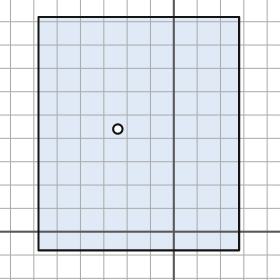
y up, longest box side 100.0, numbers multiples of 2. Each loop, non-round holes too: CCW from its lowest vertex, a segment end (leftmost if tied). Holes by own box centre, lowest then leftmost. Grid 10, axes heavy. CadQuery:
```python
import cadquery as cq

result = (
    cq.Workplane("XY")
    .moveTo(-58.0, -8.0)
    .lineTo(28.0, -8.0)
    .lineTo(28.0, 92.0)
    .lineTo(-58.0, 92.0)
    .close()
    .moveTo(-24.0, 44.0)
    .circle(2.0)
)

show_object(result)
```